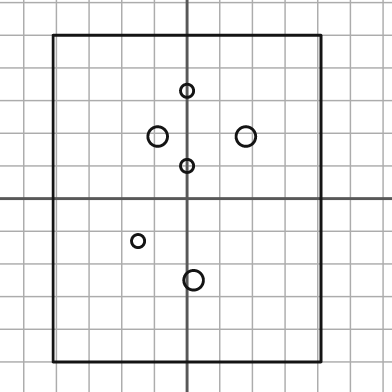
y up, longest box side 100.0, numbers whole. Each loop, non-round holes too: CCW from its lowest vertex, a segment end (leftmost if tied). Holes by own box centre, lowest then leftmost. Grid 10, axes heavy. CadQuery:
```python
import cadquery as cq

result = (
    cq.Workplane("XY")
    .moveTo(-41.0, -50.0)
    .lineTo(41.0, -50.0)
    .lineTo(41.0, 50.0)
    .lineTo(-41.0, 50.0)
    .close()
    .moveTo(2.0, -25.0)
    .circle(3.0)
    .moveTo(-15.0, -13.0)
    .circle(2.0)
    .moveTo(0.0, 10.0)
    .circle(2.0)
    .moveTo(-9.0, 19.0)
    .circle(3.0)
    .moveTo(18.0, 19.0)
    .circle(3.0)
    .moveTo(0.0, 33.0)
    .circle(2.0)
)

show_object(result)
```